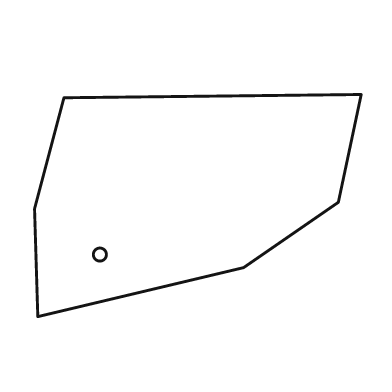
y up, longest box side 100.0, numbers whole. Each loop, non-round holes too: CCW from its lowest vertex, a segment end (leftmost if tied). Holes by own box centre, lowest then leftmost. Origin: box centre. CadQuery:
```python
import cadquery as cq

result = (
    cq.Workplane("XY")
    .moveTo(-49.0, -34.0)
    .lineTo(14.0, -19.0)
    .lineTo(43.0, 1.0)
    .lineTo(50.0, 34.0)
    .lineTo(-41.0, 33.0)
    .lineTo(-50.0, -1.0)
    .close()
    .moveTo(-30.0, -15.0)
    .circle(2.0)
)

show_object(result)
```